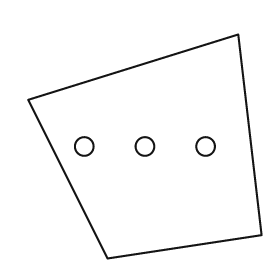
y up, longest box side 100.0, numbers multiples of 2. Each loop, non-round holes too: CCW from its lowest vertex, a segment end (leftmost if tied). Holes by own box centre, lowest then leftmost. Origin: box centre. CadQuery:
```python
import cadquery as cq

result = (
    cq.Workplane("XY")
    .moveTo(-16.0, -48.0)
    .lineTo(50.0, -38.0)
    .lineTo(40.0, 48.0)
    .lineTo(-50.0, 20.0)
    .close()
    .moveTo(-26.0, 0.0)
    .circle(4.0)
    .moveTo(0.0, 0.0)
    .circle(4.0)
    .moveTo(26.0, 0.0)
    .circle(4.0)
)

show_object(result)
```